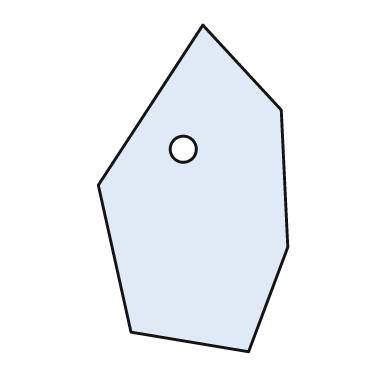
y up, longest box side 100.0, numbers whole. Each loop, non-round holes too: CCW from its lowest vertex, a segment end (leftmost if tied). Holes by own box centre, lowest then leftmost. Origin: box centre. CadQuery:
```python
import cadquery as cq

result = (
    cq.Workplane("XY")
    .moveTo(17.0, -50.0)
    .lineTo(29.0, -18.0)
    .lineTo(27.0, 24.0)
    .lineTo(3.0, 50.0)
    .lineTo(-29.0, 1.0)
    .lineTo(-19.0, -44.0)
    .close()
    .moveTo(-3.0, 12.0)
    .circle(4.0)
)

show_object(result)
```